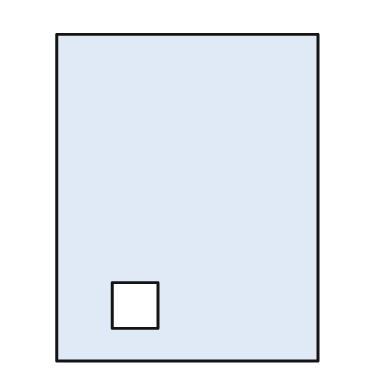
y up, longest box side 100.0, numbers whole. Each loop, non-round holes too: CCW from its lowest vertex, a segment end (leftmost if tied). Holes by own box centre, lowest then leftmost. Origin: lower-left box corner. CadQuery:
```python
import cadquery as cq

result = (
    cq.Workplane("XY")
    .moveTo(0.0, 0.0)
    .lineTo(80.0, 0.0)
    .lineTo(80.0, 100.0)
    .lineTo(0.0, 100.0)
    .close()
    .moveTo(17.0, 10.0)
    .lineTo(31.0, 10.0)
    .lineTo(31.0, 24.0)
    .lineTo(17.0, 24.0)
    .close()
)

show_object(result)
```